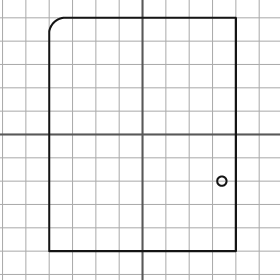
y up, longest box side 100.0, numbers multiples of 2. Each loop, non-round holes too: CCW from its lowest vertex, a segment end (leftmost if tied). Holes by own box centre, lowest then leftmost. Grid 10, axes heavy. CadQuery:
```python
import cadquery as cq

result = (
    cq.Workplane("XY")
    .moveTo(-40.0, -50.0)
    .lineTo(40.0, -50.0)
    .lineTo(40.0, 50.0)
    .lineTo(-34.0, 50.0)
    .threePointArc((-38.0, 48.0), (-40.0, 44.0))
    .close()
    .moveTo(34.0, -20.0)
    .circle(2.0)
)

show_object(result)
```